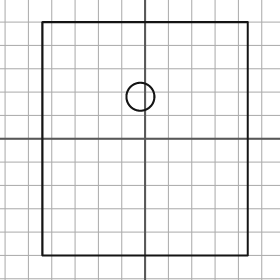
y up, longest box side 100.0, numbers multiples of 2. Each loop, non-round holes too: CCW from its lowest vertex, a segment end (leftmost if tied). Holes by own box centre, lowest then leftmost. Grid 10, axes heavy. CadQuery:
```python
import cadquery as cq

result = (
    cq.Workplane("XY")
    .moveTo(-44.0, -50.0)
    .lineTo(44.0, -50.0)
    .lineTo(44.0, 50.0)
    .lineTo(-44.0, 50.0)
    .close()
    .moveTo(-2.0, 18.0)
    .circle(6.0)
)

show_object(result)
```